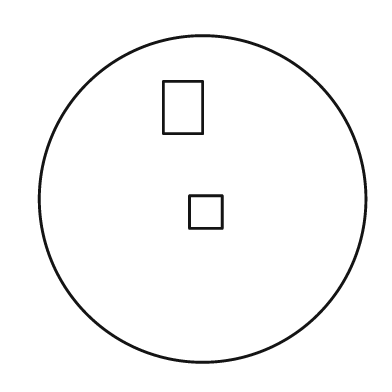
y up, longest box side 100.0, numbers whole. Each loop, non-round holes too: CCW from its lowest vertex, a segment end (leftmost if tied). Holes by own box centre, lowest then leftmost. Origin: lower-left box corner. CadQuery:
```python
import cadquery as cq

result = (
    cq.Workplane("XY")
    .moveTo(50.0, 50.0)
    .circle(50.0)
    .moveTo(46.0, 41.0)
    .lineTo(56.0, 41.0)
    .lineTo(56.0, 51.0)
    .lineTo(46.0, 51.0)
    .close()
    .moveTo(38.0, 70.0)
    .lineTo(50.0, 70.0)
    .lineTo(50.0, 86.0)
    .lineTo(38.0, 86.0)
    .close()
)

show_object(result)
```